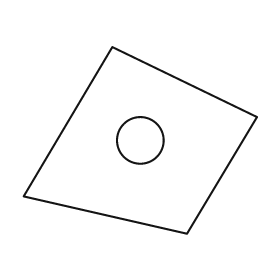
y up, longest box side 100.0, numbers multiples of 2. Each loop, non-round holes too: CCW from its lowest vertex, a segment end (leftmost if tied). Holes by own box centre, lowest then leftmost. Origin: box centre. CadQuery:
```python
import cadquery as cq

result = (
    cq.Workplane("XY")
    .moveTo(20.0, -40.0)
    .lineTo(50.0, 10.0)
    .lineTo(-12.0, 40.0)
    .lineTo(-50.0, -24.0)
    .close()
    .moveTo(0.0, 0.0)
    .circle(10.0)
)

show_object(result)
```